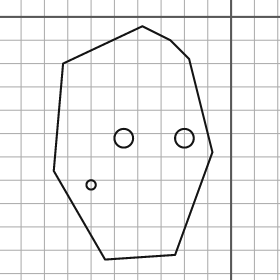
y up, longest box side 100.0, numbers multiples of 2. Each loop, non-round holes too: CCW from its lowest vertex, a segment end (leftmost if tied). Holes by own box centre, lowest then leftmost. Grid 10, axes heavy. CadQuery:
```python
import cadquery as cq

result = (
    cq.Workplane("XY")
    .moveTo(-54.0, -104.0)
    .lineTo(-24.0, -102.0)
    .lineTo(-8.0, -58.0)
    .lineTo(-18.0, -18.0)
    .lineTo(-26.0, -10.0)
    .lineTo(-38.0, -4.0)
    .lineTo(-72.0, -20.0)
    .lineTo(-76.0, -66.0)
    .close()
    .moveTo(-60.0, -72.0)
    .circle(2.0)
    .moveTo(-46.0, -52.0)
    .circle(4.0)
    .moveTo(-20.0, -52.0)
    .circle(4.0)
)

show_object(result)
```